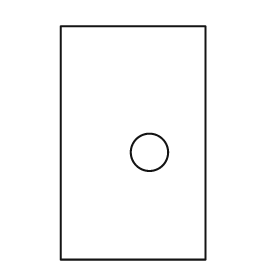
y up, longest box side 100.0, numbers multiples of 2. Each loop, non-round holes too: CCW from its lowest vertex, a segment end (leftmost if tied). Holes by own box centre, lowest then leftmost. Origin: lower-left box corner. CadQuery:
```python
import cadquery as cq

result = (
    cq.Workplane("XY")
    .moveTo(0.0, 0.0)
    .lineTo(62.0, 0.0)
    .lineTo(62.0, 100.0)
    .lineTo(0.0, 100.0)
    .close()
    .moveTo(38.0, 46.0)
    .circle(8.0)
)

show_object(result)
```